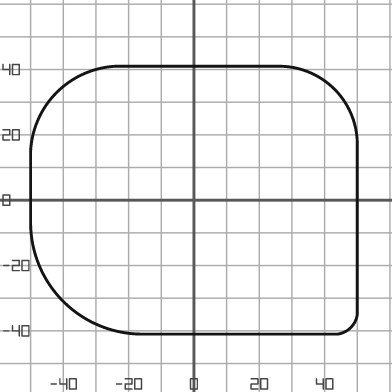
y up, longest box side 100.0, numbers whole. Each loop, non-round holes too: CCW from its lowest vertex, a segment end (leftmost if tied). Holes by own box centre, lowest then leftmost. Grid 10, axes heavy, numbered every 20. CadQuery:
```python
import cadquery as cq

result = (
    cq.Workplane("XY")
    .moveTo(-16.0, -41.0)
    .lineTo(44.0, -41.0)
    .threePointArc((48.0, -39.0), (50.0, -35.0))
    .lineTo(50.0, 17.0)
    .threePointArc((43.0, 34.0), (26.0, 41.0))
    .lineTo(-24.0, 41.0)
    .threePointArc((-42.0, 33.0), (-50.0, 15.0))
    .lineTo(-50.0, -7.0)
    .threePointArc((-40.0, -31.0), (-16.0, -41.0))
    .close()
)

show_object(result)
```